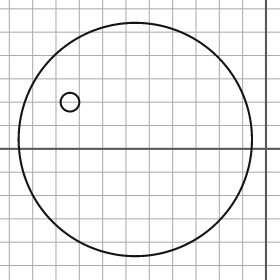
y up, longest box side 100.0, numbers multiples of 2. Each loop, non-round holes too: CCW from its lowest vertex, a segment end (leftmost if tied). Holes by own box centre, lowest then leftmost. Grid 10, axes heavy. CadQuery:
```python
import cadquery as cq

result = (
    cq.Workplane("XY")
    .moveTo(-56.0, 4.0)
    .circle(50.0)
    .moveTo(-84.0, 20.0)
    .circle(4.0)
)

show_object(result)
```